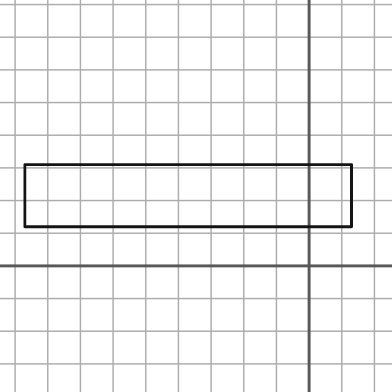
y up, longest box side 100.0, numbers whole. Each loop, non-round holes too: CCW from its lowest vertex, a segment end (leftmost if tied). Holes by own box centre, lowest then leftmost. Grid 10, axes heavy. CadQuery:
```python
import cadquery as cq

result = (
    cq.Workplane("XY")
    .moveTo(-87.0, 12.0)
    .lineTo(13.0, 12.0)
    .lineTo(13.0, 31.0)
    .lineTo(-87.0, 31.0)
    .close()
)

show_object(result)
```